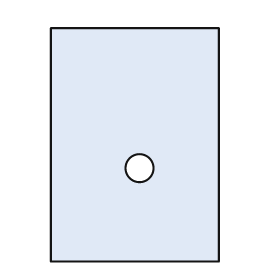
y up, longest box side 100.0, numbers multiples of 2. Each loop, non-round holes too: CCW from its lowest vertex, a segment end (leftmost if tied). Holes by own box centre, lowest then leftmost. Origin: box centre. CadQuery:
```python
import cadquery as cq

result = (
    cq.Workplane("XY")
    .moveTo(-36.0, -50.0)
    .lineTo(36.0, -50.0)
    .lineTo(36.0, 50.0)
    .lineTo(-36.0, 50.0)
    .close()
    .moveTo(2.0, -10.0)
    .circle(6.0)
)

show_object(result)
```